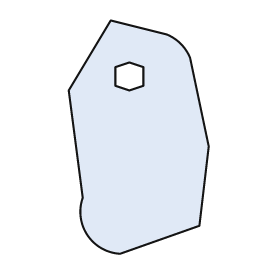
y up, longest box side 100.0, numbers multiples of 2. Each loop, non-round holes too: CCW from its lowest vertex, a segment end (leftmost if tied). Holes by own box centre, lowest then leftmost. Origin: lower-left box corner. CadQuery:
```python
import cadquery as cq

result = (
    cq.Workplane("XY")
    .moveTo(22.0, 0.0)
    .lineTo(56.0, 12.0)
    .lineTo(60.0, 46.0)
    .lineTo(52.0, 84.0)
    .threePointArc((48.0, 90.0), (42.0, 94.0))
    .lineTo(18.0, 100.0)
    .lineTo(0.0, 70.0)
    .lineTo(6.0, 24.0)
    .threePointArc((8.0, 8.0), (22.0, 0.0))
    .close()
    .moveTo(26.0, 70.0)
    .lineTo(32.0, 72.0)
    .lineTo(32.0, 80.0)
    .lineTo(26.0, 82.0)
    .lineTo(20.0, 80.0)
    .lineTo(20.0, 72.0)
    .close()
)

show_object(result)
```